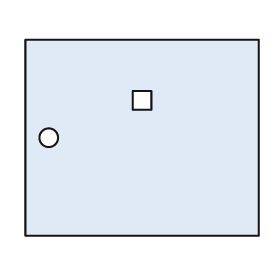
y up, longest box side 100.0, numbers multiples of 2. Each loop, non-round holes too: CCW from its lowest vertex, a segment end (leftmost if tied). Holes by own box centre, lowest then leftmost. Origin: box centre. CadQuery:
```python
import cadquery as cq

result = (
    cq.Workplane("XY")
    .moveTo(-50.0, -42.0)
    .lineTo(50.0, -42.0)
    .lineTo(50.0, 42.0)
    .lineTo(-50.0, 42.0)
    .close()
    .moveTo(-40.0, 0.0)
    .circle(4.0)
    .moveTo(-4.0, 12.0)
    .lineTo(4.0, 12.0)
    .lineTo(4.0, 20.0)
    .lineTo(-4.0, 20.0)
    .close()
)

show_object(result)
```